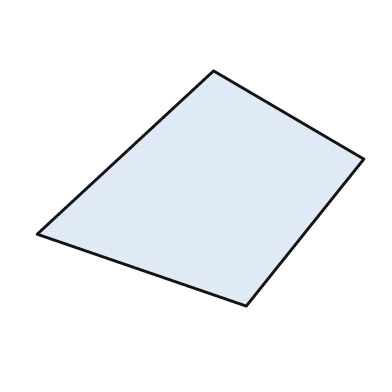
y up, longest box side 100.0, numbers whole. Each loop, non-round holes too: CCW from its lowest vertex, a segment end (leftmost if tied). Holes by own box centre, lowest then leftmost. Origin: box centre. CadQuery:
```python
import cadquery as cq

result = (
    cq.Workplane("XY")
    .moveTo(14.0, -36.0)
    .lineTo(50.0, 9.0)
    .lineTo(4.0, 36.0)
    .lineTo(-50.0, -14.0)
    .close()
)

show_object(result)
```